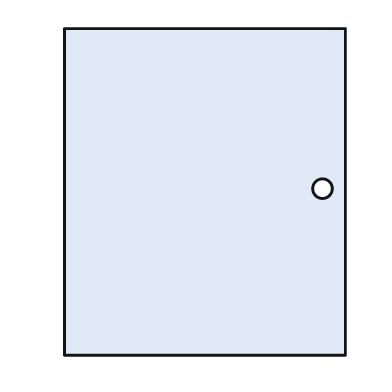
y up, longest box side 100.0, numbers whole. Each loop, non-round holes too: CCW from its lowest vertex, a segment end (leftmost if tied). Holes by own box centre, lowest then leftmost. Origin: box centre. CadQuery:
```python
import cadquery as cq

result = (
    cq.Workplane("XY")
    .moveTo(-43.0, -50.0)
    .lineTo(43.0, -50.0)
    .lineTo(43.0, 50.0)
    .lineTo(-43.0, 50.0)
    .close()
    .moveTo(36.0, 1.0)
    .circle(3.0)
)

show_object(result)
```